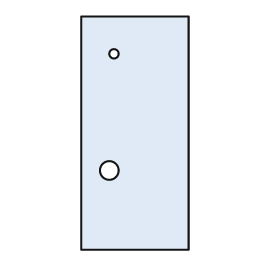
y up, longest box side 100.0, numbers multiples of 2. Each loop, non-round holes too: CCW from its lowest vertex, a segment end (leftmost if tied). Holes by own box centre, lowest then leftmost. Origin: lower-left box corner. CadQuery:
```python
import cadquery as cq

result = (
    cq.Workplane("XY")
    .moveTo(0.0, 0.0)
    .lineTo(46.0, 0.0)
    .lineTo(46.0, 100.0)
    .lineTo(0.0, 100.0)
    .close()
    .moveTo(12.0, 34.0)
    .circle(4.0)
    .moveTo(14.0, 84.0)
    .circle(2.0)
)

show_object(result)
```